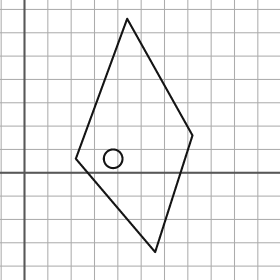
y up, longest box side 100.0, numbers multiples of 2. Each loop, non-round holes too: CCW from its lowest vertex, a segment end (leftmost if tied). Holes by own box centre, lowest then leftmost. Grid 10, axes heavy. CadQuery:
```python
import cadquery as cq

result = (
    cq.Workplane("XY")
    .moveTo(56.0, -34.0)
    .lineTo(72.0, 16.0)
    .lineTo(44.0, 66.0)
    .lineTo(22.0, 6.0)
    .close()
    .moveTo(38.0, 6.0)
    .circle(4.0)
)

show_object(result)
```